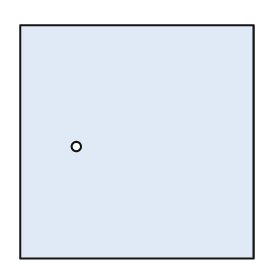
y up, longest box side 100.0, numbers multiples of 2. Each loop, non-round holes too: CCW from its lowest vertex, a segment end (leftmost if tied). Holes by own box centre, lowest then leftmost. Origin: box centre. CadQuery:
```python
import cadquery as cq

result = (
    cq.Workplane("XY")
    .moveTo(-50.0, -50.0)
    .lineTo(50.0, -50.0)
    .lineTo(50.0, 50.0)
    .lineTo(-50.0, 50.0)
    .close()
    .moveTo(-26.0, -2.0)
    .circle(2.0)
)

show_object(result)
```